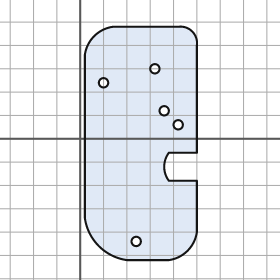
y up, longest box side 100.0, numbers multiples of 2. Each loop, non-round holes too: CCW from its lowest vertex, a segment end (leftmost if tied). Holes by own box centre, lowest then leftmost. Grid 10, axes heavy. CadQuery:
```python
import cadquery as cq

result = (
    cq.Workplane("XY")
    .moveTo(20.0, -52.0)
    .lineTo(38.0, -52.0)
    .threePointArc((46.0, -48.0), (50.0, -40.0))
    .lineTo(50.0, -18.0)
    .lineTo(38.0, -18.0)
    .threePointArc((36.0, -12.0), (38.0, -6.0))
    .lineTo(50.0, -6.0)
    .lineTo(50.0, 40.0)
    .threePointArc((48.0, 46.0), (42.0, 48.0))
    .lineTo(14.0, 48.0)
    .threePointArc((6.0, 44.0), (2.0, 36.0))
    .lineTo(2.0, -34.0)
    .threePointArc((8.0, -46.0), (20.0, -52.0))
    .close()
    .moveTo(24.0, -44.0)
    .circle(2.0)
    .moveTo(42.0, 6.0)
    .circle(2.0)
    .moveTo(36.0, 12.0)
    .circle(2.0)
    .moveTo(10.0, 24.0)
    .circle(2.0)
    .moveTo(32.0, 30.0)
    .circle(2.0)
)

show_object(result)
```